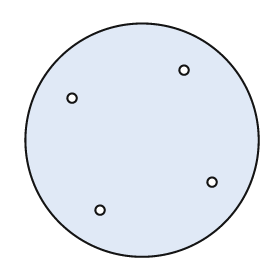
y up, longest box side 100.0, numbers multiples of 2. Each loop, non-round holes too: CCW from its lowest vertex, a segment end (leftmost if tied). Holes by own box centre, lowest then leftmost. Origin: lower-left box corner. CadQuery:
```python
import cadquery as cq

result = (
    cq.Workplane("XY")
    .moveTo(50.0, 50.0)
    .circle(50.0)
    .moveTo(32.0, 20.0)
    .circle(2.0)
    .moveTo(80.0, 32.0)
    .circle(2.0)
    .moveTo(20.0, 68.0)
    .circle(2.0)
    .moveTo(68.0, 80.0)
    .circle(2.0)
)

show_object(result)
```